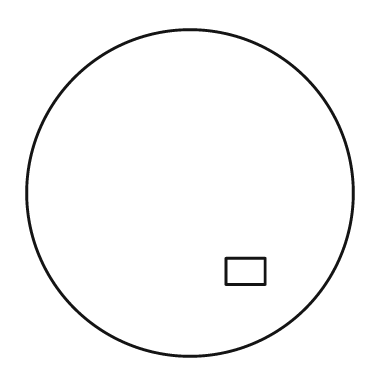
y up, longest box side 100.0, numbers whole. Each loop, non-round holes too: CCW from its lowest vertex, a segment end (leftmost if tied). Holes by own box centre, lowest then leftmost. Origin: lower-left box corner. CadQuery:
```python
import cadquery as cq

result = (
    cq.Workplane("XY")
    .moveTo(50.0, 50.0)
    .circle(50.0)
    .moveTo(61.0, 22.0)
    .lineTo(73.0, 22.0)
    .lineTo(73.0, 30.0)
    .lineTo(61.0, 30.0)
    .close()
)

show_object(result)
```